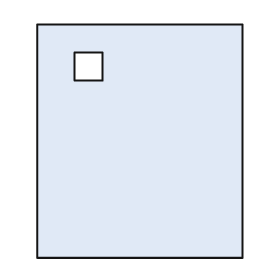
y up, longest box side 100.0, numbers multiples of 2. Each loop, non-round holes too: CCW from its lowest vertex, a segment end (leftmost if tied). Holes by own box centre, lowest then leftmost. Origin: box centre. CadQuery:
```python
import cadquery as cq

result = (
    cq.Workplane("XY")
    .moveTo(-44.0, -50.0)
    .lineTo(44.0, -50.0)
    .lineTo(44.0, 50.0)
    .lineTo(-44.0, 50.0)
    .close()
    .moveTo(-28.0, 26.0)
    .lineTo(-16.0, 26.0)
    .lineTo(-16.0, 38.0)
    .lineTo(-28.0, 38.0)
    .close()
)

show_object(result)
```